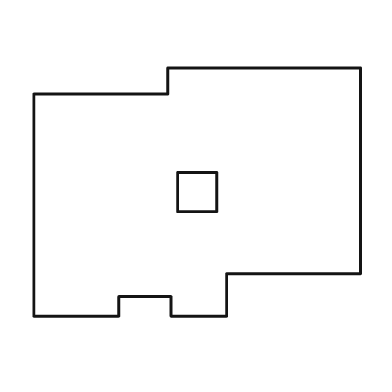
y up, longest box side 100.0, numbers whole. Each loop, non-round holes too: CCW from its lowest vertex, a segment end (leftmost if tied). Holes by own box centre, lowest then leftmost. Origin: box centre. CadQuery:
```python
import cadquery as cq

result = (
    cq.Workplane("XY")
    .moveTo(-50.0, -38.0)
    .lineTo(-24.0, -38.0)
    .lineTo(-24.0, -32.0)
    .lineTo(-8.0, -32.0)
    .lineTo(-8.0, -38.0)
    .lineTo(9.0, -38.0)
    .lineTo(9.0, -25.0)
    .lineTo(50.0, -25.0)
    .lineTo(50.0, 38.0)
    .lineTo(-9.0, 38.0)
    .lineTo(-9.0, 30.0)
    .lineTo(-50.0, 30.0)
    .close()
    .moveTo(-6.0, -6.0)
    .lineTo(6.0, -6.0)
    .lineTo(6.0, 6.0)
    .lineTo(-6.0, 6.0)
    .close()
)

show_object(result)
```